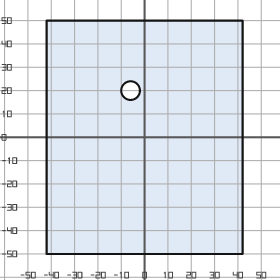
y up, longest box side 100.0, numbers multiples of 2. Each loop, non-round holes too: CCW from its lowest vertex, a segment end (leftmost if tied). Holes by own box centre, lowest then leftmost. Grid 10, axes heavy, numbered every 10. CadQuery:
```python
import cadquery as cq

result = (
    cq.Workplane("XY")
    .moveTo(-42.0, -50.0)
    .lineTo(42.0, -50.0)
    .lineTo(42.0, 50.0)
    .lineTo(-42.0, 50.0)
    .close()
    .moveTo(-6.0, 20.0)
    .circle(4.0)
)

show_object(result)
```